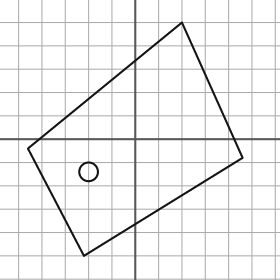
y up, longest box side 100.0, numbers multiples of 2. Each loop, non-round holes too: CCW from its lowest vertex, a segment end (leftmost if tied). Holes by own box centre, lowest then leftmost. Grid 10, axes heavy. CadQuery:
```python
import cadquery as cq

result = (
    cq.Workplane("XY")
    .moveTo(-22.0, -50.0)
    .lineTo(46.0, -8.0)
    .lineTo(20.0, 50.0)
    .lineTo(-46.0, -4.0)
    .close()
    .moveTo(-20.0, -14.0)
    .circle(4.0)
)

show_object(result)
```